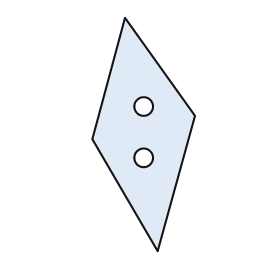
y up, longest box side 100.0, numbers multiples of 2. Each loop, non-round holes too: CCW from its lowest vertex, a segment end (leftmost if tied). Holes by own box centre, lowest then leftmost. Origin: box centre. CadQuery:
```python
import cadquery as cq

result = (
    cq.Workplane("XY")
    .moveTo(6.0, -50.0)
    .lineTo(22.0, 8.0)
    .lineTo(-8.0, 50.0)
    .lineTo(-22.0, -2.0)
    .close()
    .moveTo(0.0, -10.0)
    .circle(4.0)
    .moveTo(0.0, 12.0)
    .circle(4.0)
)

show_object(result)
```